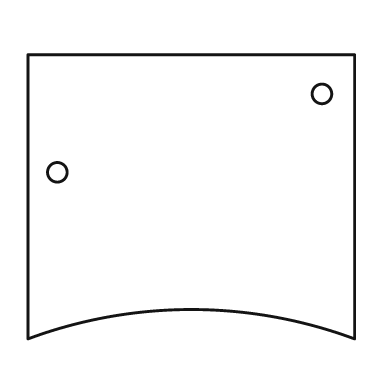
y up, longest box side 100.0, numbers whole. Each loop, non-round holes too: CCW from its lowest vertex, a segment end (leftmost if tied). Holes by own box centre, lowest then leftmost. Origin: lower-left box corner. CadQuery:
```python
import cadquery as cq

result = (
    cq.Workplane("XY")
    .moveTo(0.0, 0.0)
    .threePointArc((50.0, 9.0), (100.0, 0.0))
    .lineTo(100.0, 87.0)
    .lineTo(0.0, 87.0)
    .close()
    .moveTo(9.0, 51.0)
    .circle(3.0)
    .moveTo(90.0, 75.0)
    .circle(3.0)
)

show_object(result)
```